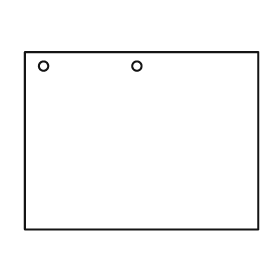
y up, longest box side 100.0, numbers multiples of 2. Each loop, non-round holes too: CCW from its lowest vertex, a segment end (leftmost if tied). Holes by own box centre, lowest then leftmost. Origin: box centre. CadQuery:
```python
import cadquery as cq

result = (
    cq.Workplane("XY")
    .moveTo(-50.0, -38.0)
    .lineTo(50.0, -38.0)
    .lineTo(50.0, 38.0)
    .lineTo(-50.0, 38.0)
    .close()
    .moveTo(-42.0, 32.0)
    .circle(2.0)
    .moveTo(-2.0, 32.0)
    .circle(2.0)
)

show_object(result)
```